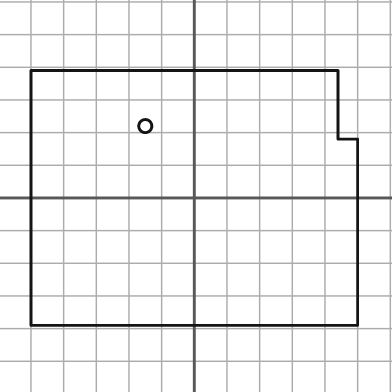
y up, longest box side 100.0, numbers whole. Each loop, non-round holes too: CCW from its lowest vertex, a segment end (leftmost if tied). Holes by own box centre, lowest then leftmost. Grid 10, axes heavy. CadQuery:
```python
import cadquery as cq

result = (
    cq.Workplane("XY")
    .moveTo(-50.0, -39.0)
    .lineTo(50.0, -39.0)
    .lineTo(50.0, 18.0)
    .lineTo(44.0, 18.0)
    .lineTo(44.0, 39.0)
    .lineTo(-50.0, 39.0)
    .close()
    .moveTo(-15.0, 22.0)
    .circle(2.0)
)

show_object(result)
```